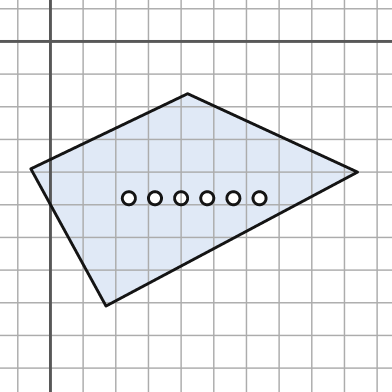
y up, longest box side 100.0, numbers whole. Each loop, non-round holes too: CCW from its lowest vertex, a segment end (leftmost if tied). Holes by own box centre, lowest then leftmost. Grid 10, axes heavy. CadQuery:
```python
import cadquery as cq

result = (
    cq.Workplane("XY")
    .moveTo(17.0, -81.0)
    .lineTo(94.0, -40.0)
    .lineTo(42.0, -16.0)
    .lineTo(-6.0, -39.0)
    .close()
    .moveTo(24.0, -48.0)
    .circle(2.0)
    .moveTo(32.0, -48.0)
    .circle(2.0)
    .moveTo(40.0, -48.0)
    .circle(2.0)
    .moveTo(48.0, -48.0)
    .circle(2.0)
    .moveTo(56.0, -48.0)
    .circle(2.0)
    .moveTo(64.0, -48.0)
    .circle(2.0)
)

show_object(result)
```